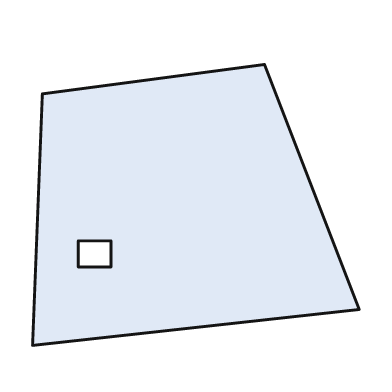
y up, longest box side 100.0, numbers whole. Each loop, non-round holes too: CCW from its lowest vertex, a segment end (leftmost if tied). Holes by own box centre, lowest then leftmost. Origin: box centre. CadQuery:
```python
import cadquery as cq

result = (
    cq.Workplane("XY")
    .moveTo(-50.0, -43.0)
    .lineTo(50.0, -32.0)
    .lineTo(21.0, 43.0)
    .lineTo(-47.0, 34.0)
    .close()
    .moveTo(-36.0, -19.0)
    .lineTo(-26.0, -19.0)
    .lineTo(-26.0, -11.0)
    .lineTo(-36.0, -11.0)
    .close()
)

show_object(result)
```